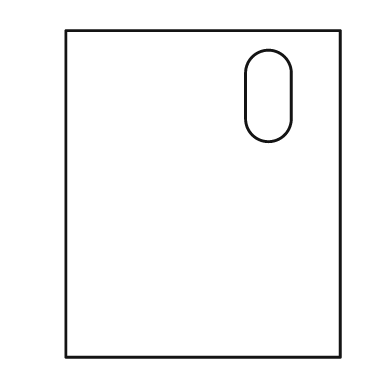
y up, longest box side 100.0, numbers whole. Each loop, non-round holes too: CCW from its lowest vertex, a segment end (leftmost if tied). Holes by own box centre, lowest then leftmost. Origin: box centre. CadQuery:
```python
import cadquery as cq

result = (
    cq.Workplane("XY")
    .moveTo(-42.0, -50.0)
    .lineTo(42.0, -50.0)
    .lineTo(42.0, 50.0)
    .lineTo(-42.0, 50.0)
    .close()
    .moveTo(13.0, 23.0)
    .threePointArc((20.0, 16.0), (27.0, 23.0))
    .lineTo(27.0, 37.0)
    .threePointArc((20.0, 44.0), (13.0, 37.0))
    .close()
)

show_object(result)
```